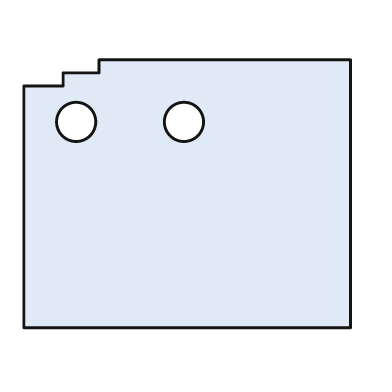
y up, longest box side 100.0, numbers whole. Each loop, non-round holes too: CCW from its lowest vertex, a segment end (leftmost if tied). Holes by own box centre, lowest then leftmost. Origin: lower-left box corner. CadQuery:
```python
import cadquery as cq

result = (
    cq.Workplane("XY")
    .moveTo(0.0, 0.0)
    .lineTo(100.0, 0.0)
    .lineTo(100.0, 82.0)
    .lineTo(23.0, 82.0)
    .lineTo(23.0, 78.0)
    .lineTo(12.0, 78.0)
    .lineTo(12.0, 74.0)
    .lineTo(0.0, 74.0)
    .close()
    .moveTo(16.0, 63.0)
    .circle(6.0)
    .moveTo(49.0, 63.0)
    .circle(6.0)
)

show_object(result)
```